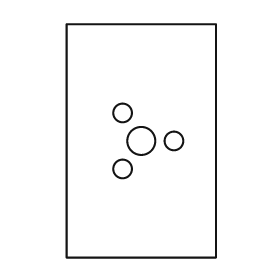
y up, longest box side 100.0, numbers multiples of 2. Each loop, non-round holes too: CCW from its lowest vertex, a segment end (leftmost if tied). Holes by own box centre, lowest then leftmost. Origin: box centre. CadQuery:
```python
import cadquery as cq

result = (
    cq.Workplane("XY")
    .moveTo(-32.0, -50.0)
    .lineTo(32.0, -50.0)
    .lineTo(32.0, 50.0)
    .lineTo(-32.0, 50.0)
    .close()
    .moveTo(-8.0, -12.0)
    .circle(4.0)
    .moveTo(0.0, 0.0)
    .circle(6.0)
    .moveTo(14.0, 0.0)
    .circle(4.0)
    .moveTo(-8.0, 12.0)
    .circle(4.0)
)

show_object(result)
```